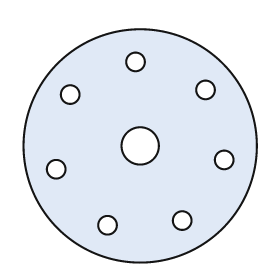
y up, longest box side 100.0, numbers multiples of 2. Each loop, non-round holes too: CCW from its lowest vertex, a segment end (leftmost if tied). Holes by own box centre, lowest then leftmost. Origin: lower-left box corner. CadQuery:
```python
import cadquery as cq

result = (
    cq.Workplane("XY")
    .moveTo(50.0, 50.0)
    .circle(50.0)
    .moveTo(36.0, 16.0)
    .circle(4.0)
    .moveTo(68.0, 18.0)
    .circle(4.0)
    .moveTo(14.0, 40.0)
    .circle(4.0)
    .moveTo(86.0, 44.0)
    .circle(4.0)
    .moveTo(50.0, 50.0)
    .circle(8.0)
    .moveTo(20.0, 72.0)
    .circle(4.0)
    .moveTo(78.0, 74.0)
    .circle(4.0)
    .moveTo(48.0, 86.0)
    .circle(4.0)
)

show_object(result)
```